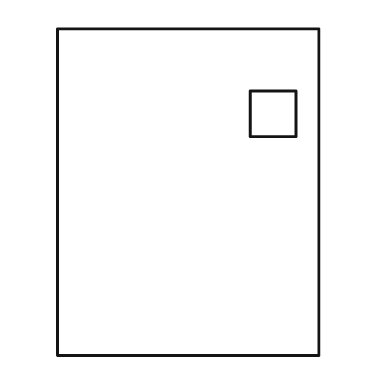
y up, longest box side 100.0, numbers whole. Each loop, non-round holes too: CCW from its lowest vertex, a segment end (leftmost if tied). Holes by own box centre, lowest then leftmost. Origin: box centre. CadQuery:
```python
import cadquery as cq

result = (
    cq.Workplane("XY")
    .moveTo(-40.0, -50.0)
    .lineTo(40.0, -50.0)
    .lineTo(40.0, 50.0)
    .lineTo(-40.0, 50.0)
    .close()
    .moveTo(19.0, 17.0)
    .lineTo(33.0, 17.0)
    .lineTo(33.0, 31.0)
    .lineTo(19.0, 31.0)
    .close()
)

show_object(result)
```